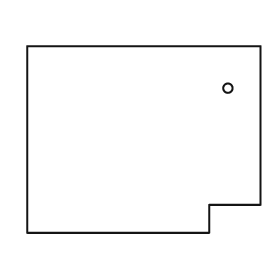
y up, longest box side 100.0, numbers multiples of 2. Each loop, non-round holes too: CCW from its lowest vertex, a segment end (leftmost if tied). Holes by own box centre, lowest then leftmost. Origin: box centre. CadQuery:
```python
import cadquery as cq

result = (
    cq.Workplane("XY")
    .moveTo(-50.0, -40.0)
    .lineTo(28.0, -40.0)
    .lineTo(28.0, -28.0)
    .lineTo(50.0, -28.0)
    .lineTo(50.0, 40.0)
    .lineTo(-50.0, 40.0)
    .close()
    .moveTo(36.0, 22.0)
    .circle(2.0)
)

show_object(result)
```